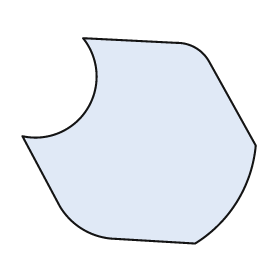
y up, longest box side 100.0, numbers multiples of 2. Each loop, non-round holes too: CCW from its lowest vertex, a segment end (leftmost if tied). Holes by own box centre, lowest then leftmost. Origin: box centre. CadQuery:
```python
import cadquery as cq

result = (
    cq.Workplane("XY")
    .moveTo(24.0, -44.0)
    .threePointArc((42.0, -26.0), (50.0, -2.0))
    .lineTo(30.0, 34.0)
    .threePointArc((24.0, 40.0), (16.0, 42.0))
    .lineTo(-24.0, 44.0)
    .threePointArc((-22.0, 14.0), (-50.0, 2.0))
    .lineTo(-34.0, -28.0)
    .threePointArc((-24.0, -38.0), (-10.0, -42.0))
    .close()
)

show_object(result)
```